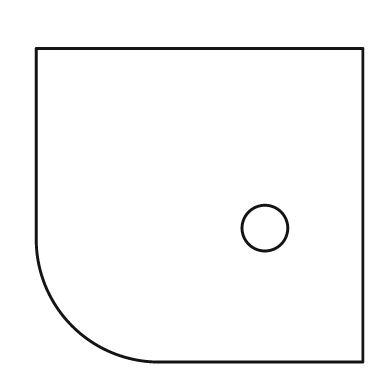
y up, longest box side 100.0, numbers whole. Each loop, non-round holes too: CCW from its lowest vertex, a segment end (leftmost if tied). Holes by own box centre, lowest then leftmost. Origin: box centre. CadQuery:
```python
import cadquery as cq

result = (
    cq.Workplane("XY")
    .moveTo(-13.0, -48.0)
    .lineTo(50.0, -48.0)
    .lineTo(50.0, 48.0)
    .lineTo(-50.0, 48.0)
    .lineTo(-50.0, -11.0)
    .threePointArc((-39.0, -37.0), (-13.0, -48.0))
    .close()
    .moveTo(20.0, -7.0)
    .circle(7.0)
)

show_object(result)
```